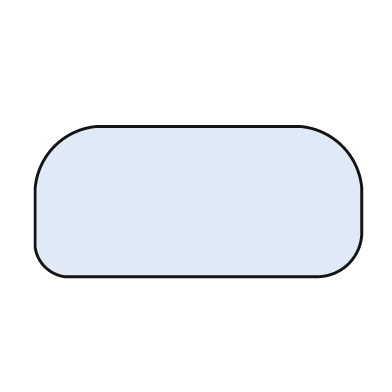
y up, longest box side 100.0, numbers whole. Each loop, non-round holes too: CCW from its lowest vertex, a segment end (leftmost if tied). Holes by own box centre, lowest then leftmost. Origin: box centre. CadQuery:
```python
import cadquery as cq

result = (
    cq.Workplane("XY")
    .moveTo(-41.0, -23.0)
    .lineTo(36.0, -23.0)
    .threePointArc((46.0, -19.0), (50.0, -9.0))
    .lineTo(50.0, 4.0)
    .threePointArc((44.0, 17.0), (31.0, 23.0))
    .lineTo(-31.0, 23.0)
    .threePointArc((-44.0, 17.0), (-50.0, 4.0))
    .lineTo(-50.0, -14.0)
    .threePointArc((-47.0, -20.0), (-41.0, -23.0))
    .close()
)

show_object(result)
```